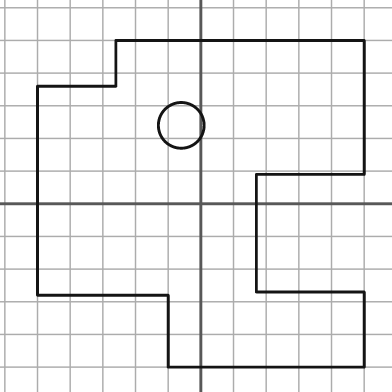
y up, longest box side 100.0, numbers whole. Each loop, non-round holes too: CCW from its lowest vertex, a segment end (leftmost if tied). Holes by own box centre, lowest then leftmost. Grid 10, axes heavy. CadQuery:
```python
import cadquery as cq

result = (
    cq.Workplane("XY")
    .moveTo(-10.0, -50.0)
    .lineTo(50.0, -50.0)
    .lineTo(50.0, -27.0)
    .lineTo(17.0, -27.0)
    .lineTo(17.0, 9.0)
    .lineTo(50.0, 9.0)
    .lineTo(50.0, 50.0)
    .lineTo(-26.0, 50.0)
    .lineTo(-26.0, 36.0)
    .lineTo(-50.0, 36.0)
    .lineTo(-50.0, -28.0)
    .lineTo(-10.0, -28.0)
    .close()
    .moveTo(-6.0, 24.0)
    .circle(7.0)
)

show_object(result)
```